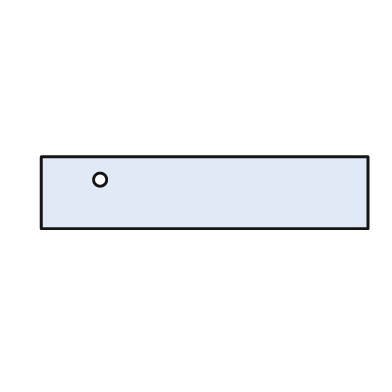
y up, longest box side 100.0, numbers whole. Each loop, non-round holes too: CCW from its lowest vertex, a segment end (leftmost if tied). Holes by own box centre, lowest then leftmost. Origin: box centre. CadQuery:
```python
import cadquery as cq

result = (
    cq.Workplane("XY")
    .moveTo(-50.0, -11.0)
    .lineTo(50.0, -11.0)
    .lineTo(50.0, 11.0)
    .lineTo(-50.0, 11.0)
    .close()
    .moveTo(-32.0, 4.0)
    .circle(2.0)
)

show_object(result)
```